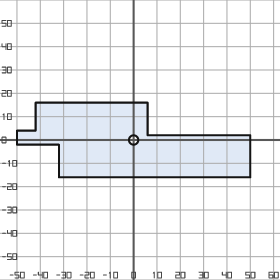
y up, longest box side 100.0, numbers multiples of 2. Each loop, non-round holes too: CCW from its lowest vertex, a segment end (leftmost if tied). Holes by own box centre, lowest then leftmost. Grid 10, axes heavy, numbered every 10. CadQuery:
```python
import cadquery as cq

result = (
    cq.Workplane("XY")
    .moveTo(-32.0, -16.0)
    .lineTo(50.0, -16.0)
    .lineTo(50.0, 2.0)
    .lineTo(6.0, 2.0)
    .lineTo(6.0, 16.0)
    .lineTo(-42.0, 16.0)
    .lineTo(-42.0, 4.0)
    .lineTo(-50.0, 4.0)
    .lineTo(-50.0, -2.0)
    .lineTo(-32.0, -2.0)
    .close()
    .moveTo(0.0, 0.0)
    .circle(2.0)
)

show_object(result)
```